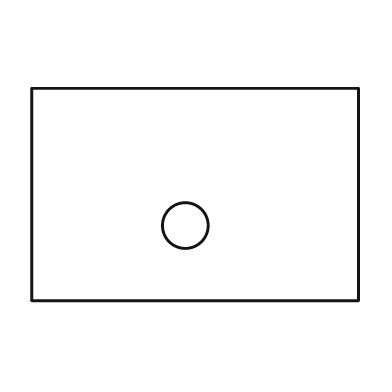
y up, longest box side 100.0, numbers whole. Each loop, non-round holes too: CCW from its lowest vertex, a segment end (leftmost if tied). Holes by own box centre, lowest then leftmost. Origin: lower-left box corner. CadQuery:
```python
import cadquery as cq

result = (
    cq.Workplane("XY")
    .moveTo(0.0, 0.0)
    .lineTo(100.0, 0.0)
    .lineTo(100.0, 65.0)
    .lineTo(0.0, 65.0)
    .close()
    .moveTo(47.0, 23.0)
    .circle(7.0)
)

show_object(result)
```